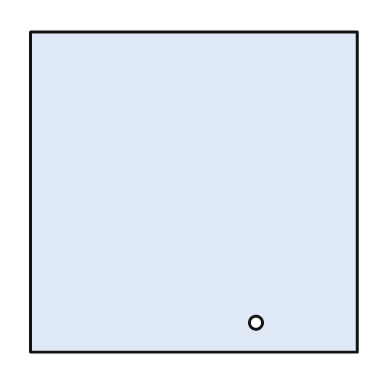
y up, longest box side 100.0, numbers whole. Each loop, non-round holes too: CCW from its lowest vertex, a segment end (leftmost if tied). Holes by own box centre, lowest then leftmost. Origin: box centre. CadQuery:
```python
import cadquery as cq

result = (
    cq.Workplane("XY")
    .moveTo(-50.0, -49.0)
    .lineTo(50.0, -49.0)
    .lineTo(50.0, 49.0)
    .lineTo(-50.0, 49.0)
    .close()
    .moveTo(19.0, -40.0)
    .circle(2.0)
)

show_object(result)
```